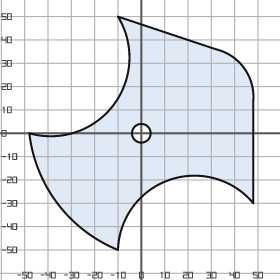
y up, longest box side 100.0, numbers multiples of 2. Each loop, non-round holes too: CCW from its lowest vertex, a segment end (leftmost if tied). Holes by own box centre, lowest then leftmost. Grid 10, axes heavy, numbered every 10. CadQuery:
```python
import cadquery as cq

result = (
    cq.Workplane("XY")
    .moveTo(-10.0, -50.0)
    .threePointArc((12.0, -20.0), (48.0, -30.0))
    .lineTo(48.0, 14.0)
    .threePointArc((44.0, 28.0), (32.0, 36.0))
    .lineTo(-10.0, 50.0)
    .threePointArc((-12.0, 12.0), (-48.0, 0.0))
    .threePointArc((-36.0, -30.0), (-10.0, -50.0))
    .close()
    .moveTo(0.0, 0.0)
    .circle(4.0)
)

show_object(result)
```